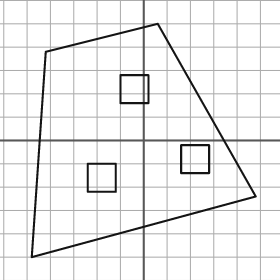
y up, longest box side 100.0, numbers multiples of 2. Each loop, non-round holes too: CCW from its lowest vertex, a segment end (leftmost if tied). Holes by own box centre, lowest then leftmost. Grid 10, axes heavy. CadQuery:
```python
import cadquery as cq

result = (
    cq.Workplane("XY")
    .moveTo(-48.0, -50.0)
    .lineTo(48.0, -24.0)
    .lineTo(6.0, 50.0)
    .lineTo(-42.0, 38.0)
    .close()
    .moveTo(-24.0, -22.0)
    .lineTo(-12.0, -22.0)
    .lineTo(-12.0, -10.0)
    .lineTo(-24.0, -10.0)
    .close()
    .moveTo(16.0, -14.0)
    .lineTo(28.0, -14.0)
    .lineTo(28.0, -2.0)
    .lineTo(16.0, -2.0)
    .close()
    .moveTo(-10.0, 16.0)
    .lineTo(2.0, 16.0)
    .lineTo(2.0, 28.0)
    .lineTo(-10.0, 28.0)
    .close()
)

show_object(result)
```